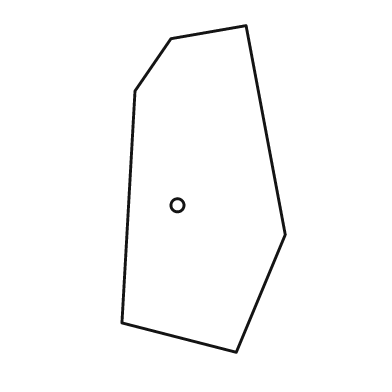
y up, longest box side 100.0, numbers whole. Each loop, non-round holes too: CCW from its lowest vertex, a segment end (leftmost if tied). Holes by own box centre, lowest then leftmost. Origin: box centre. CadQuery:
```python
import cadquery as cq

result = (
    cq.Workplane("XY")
    .moveTo(10.0, -50.0)
    .lineTo(25.0, -14.0)
    .lineTo(13.0, 50.0)
    .lineTo(-10.0, 46.0)
    .lineTo(-21.0, 30.0)
    .lineTo(-25.0, -41.0)
    .close()
    .moveTo(-8.0, -5.0)
    .circle(2.0)
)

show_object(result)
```